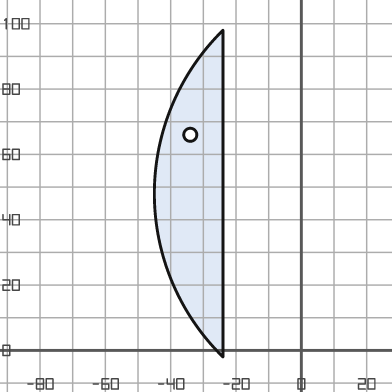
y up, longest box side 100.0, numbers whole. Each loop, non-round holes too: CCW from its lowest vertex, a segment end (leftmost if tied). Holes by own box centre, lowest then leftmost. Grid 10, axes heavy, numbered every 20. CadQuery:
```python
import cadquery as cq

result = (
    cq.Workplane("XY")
    .moveTo(-24.0, -2.0)
    .lineTo(-24.0, 98.0)
    .threePointArc((-45.0, 48.0), (-24.0, -2.0))
    .close()
    .moveTo(-34.0, 66.0)
    .circle(2.0)
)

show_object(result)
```